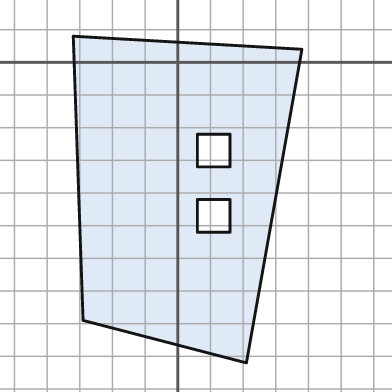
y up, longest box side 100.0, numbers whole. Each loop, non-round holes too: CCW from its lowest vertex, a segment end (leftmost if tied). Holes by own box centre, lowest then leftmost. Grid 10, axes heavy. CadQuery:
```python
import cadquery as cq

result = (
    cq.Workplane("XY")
    .moveTo(21.0, -92.0)
    .lineTo(38.0, 4.0)
    .lineTo(-32.0, 8.0)
    .lineTo(-29.0, -79.0)
    .close()
    .moveTo(6.0, -52.0)
    .lineTo(16.0, -52.0)
    .lineTo(16.0, -42.0)
    .lineTo(6.0, -42.0)
    .close()
    .moveTo(6.0, -32.0)
    .lineTo(16.0, -32.0)
    .lineTo(16.0, -22.0)
    .lineTo(6.0, -22.0)
    .close()
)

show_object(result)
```